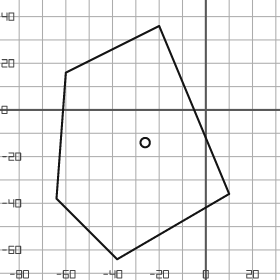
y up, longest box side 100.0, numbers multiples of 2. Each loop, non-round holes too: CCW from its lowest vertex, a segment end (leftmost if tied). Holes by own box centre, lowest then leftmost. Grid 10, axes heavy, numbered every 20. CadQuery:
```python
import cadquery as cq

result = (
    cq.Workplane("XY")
    .moveTo(-38.0, -64.0)
    .lineTo(10.0, -36.0)
    .lineTo(-20.0, 36.0)
    .lineTo(-60.0, 16.0)
    .lineTo(-64.0, -38.0)
    .close()
    .moveTo(-26.0, -14.0)
    .circle(2.0)
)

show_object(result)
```